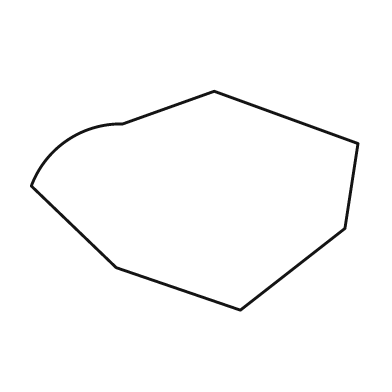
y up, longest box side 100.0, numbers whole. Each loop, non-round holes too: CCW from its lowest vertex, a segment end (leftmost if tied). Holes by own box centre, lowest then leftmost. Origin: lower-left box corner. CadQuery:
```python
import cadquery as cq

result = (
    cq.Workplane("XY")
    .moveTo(64.0, 0.0)
    .lineTo(96.0, 25.0)
    .lineTo(100.0, 51.0)
    .lineTo(56.0, 67.0)
    .lineTo(28.0, 57.0)
    .threePointArc((11.0, 52.0), (0.0, 38.0))
    .lineTo(26.0, 13.0)
    .close()
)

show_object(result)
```